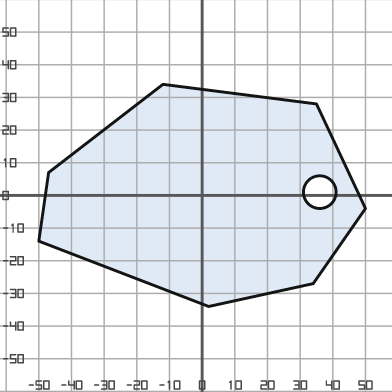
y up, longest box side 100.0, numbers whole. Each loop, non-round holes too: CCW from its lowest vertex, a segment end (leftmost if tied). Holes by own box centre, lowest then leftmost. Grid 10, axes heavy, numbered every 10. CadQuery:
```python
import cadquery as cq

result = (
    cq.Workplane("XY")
    .moveTo(2.0, -34.0)
    .lineTo(34.0, -27.0)
    .lineTo(50.0, -4.0)
    .lineTo(35.0, 28.0)
    .lineTo(-12.0, 34.0)
    .lineTo(-47.0, 7.0)
    .lineTo(-50.0, -14.0)
    .close()
    .moveTo(36.0, 1.0)
    .circle(5.0)
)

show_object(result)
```